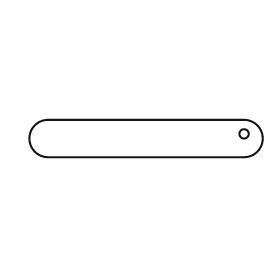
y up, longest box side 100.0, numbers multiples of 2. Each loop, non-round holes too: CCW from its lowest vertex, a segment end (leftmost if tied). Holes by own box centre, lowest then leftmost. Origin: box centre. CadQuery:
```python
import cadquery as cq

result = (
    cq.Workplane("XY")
    .moveTo(-42.0, -8.0)
    .lineTo(42.0, -8.0)
    .threePointArc((50.0, 0.0), (42.0, 8.0))
    .lineTo(-42.0, 8.0)
    .threePointArc((-50.0, 0.0), (-42.0, -8.0))
    .close()
    .moveTo(42.0, 2.0)
    .circle(2.0)
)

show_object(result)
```